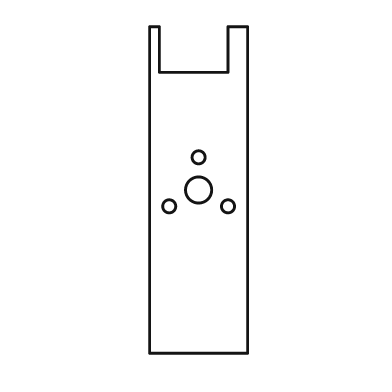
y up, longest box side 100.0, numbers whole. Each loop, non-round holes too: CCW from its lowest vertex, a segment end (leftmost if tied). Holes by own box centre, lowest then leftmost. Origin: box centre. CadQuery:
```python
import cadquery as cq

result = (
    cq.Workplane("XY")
    .moveTo(-15.0, -50.0)
    .lineTo(15.0, -50.0)
    .lineTo(15.0, 50.0)
    .lineTo(9.0, 50.0)
    .lineTo(9.0, 36.0)
    .lineTo(-12.0, 36.0)
    .lineTo(-12.0, 50.0)
    .lineTo(-15.0, 50.0)
    .close()
    .moveTo(-9.0, -5.0)
    .circle(2.0)
    .moveTo(9.0, -5.0)
    .circle(2.0)
    .moveTo(0.0, 0.0)
    .circle(4.0)
    .moveTo(0.0, 10.0)
    .circle(2.0)
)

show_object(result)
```